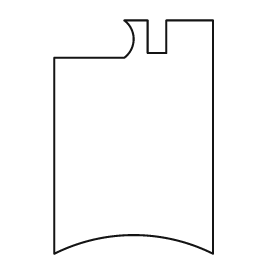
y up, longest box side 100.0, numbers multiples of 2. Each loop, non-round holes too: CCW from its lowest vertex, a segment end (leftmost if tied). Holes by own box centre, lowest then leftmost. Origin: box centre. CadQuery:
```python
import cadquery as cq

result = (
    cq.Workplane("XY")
    .moveTo(-34.0, -50.0)
    .threePointArc((0.0, -42.0), (34.0, -50.0))
    .lineTo(34.0, 50.0)
    .lineTo(14.0, 50.0)
    .lineTo(14.0, 36.0)
    .lineTo(6.0, 36.0)
    .lineTo(6.0, 50.0)
    .lineTo(-4.0, 50.0)
    .threePointArc((0.0, 42.0), (-4.0, 34.0))
    .lineTo(-34.0, 34.0)
    .close()
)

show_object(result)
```